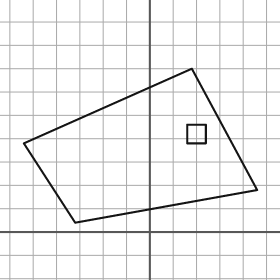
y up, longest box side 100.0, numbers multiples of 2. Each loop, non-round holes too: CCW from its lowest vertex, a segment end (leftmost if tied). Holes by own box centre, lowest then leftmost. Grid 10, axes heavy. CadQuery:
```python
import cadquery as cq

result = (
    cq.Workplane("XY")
    .moveTo(-32.0, 4.0)
    .lineTo(46.0, 18.0)
    .lineTo(18.0, 70.0)
    .lineTo(-54.0, 38.0)
    .close()
    .moveTo(16.0, 38.0)
    .lineTo(24.0, 38.0)
    .lineTo(24.0, 46.0)
    .lineTo(16.0, 46.0)
    .close()
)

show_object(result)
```